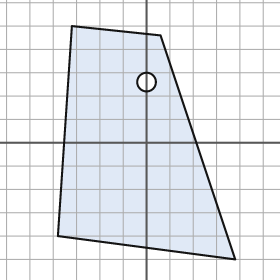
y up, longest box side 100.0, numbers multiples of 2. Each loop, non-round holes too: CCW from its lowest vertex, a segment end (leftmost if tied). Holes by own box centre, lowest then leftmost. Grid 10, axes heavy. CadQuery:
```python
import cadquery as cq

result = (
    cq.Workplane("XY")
    .moveTo(38.0, -50.0)
    .lineTo(6.0, 46.0)
    .lineTo(-32.0, 50.0)
    .lineTo(-38.0, -40.0)
    .close()
    .moveTo(0.0, 26.0)
    .circle(4.0)
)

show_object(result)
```